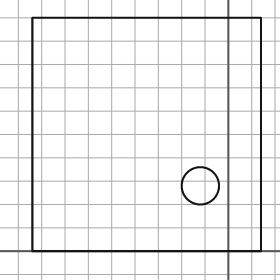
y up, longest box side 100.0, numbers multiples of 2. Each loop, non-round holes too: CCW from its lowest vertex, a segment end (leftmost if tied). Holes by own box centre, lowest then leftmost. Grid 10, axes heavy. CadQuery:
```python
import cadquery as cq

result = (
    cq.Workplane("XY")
    .moveTo(-84.0, 0.0)
    .lineTo(14.0, 0.0)
    .lineTo(14.0, 100.0)
    .lineTo(-84.0, 100.0)
    .close()
    .moveTo(-12.0, 28.0)
    .circle(8.0)
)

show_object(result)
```